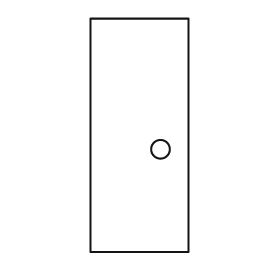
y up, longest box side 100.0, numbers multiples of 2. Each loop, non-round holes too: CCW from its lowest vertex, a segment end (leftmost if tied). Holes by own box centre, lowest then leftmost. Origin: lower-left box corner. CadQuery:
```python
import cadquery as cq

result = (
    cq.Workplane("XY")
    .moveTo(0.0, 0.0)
    .lineTo(42.0, 0.0)
    .lineTo(42.0, 100.0)
    .lineTo(0.0, 100.0)
    .close()
    .moveTo(30.0, 44.0)
    .circle(4.0)
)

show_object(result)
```